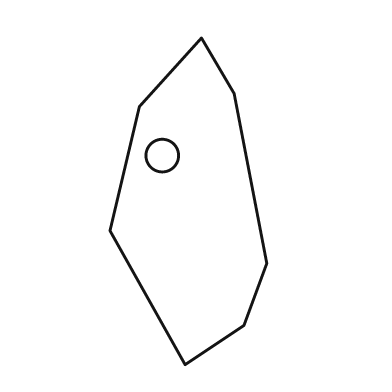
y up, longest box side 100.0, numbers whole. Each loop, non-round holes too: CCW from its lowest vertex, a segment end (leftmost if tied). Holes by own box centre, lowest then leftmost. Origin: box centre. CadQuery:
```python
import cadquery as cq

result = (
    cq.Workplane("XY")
    .moveTo(-1.0, -50.0)
    .lineTo(17.0, -38.0)
    .lineTo(24.0, -19.0)
    .lineTo(14.0, 33.0)
    .lineTo(4.0, 50.0)
    .lineTo(-15.0, 29.0)
    .lineTo(-24.0, -9.0)
    .close()
    .moveTo(-8.0, 14.0)
    .circle(5.0)
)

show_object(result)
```